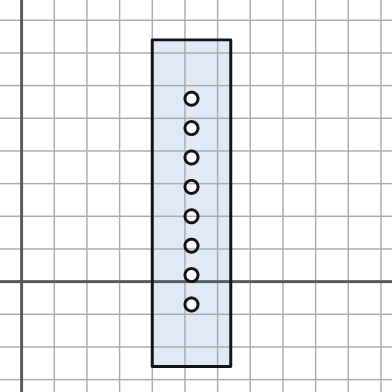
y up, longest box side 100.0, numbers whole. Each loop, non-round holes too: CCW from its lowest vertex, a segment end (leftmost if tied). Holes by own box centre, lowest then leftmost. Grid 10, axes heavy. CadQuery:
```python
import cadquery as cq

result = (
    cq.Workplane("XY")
    .moveTo(40.0, -26.0)
    .lineTo(64.0, -26.0)
    .lineTo(64.0, 74.0)
    .lineTo(40.0, 74.0)
    .close()
    .moveTo(52.0, -7.0)
    .circle(2.0)
    .moveTo(52.0, 2.0)
    .circle(2.0)
    .moveTo(52.0, 11.0)
    .circle(2.0)
    .moveTo(52.0, 20.0)
    .circle(2.0)
    .moveTo(52.0, 29.0)
    .circle(2.0)
    .moveTo(52.0, 38.0)
    .circle(2.0)
    .moveTo(52.0, 47.0)
    .circle(2.0)
    .moveTo(52.0, 56.0)
    .circle(2.0)
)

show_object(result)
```